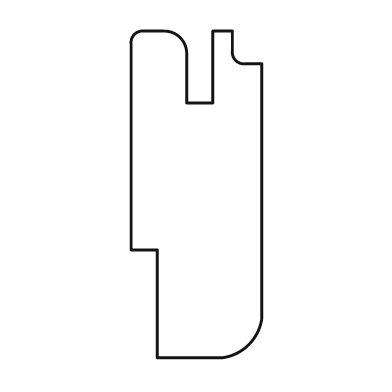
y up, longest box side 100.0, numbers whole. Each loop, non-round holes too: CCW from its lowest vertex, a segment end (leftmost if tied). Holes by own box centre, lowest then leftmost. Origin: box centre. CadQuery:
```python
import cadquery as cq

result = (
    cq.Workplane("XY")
    .moveTo(-12.0, -50.0)
    .lineTo(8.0, -50.0)
    .threePointArc((16.0, -46.0), (20.0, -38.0))
    .lineTo(20.0, 40.0)
    .lineTo(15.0, 40.0)
    .threePointArc((12.0, 41.0), (11.0, 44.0))
    .lineTo(11.0, 50.0)
    .lineTo(5.0, 50.0)
    .lineTo(5.0, 28.0)
    .lineTo(-3.0, 28.0)
    .lineTo(-3.0, 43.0)
    .threePointArc((-5.0, 48.0), (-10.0, 50.0))
    .lineTo(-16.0, 50.0)
    .threePointArc((-19.0, 49.0), (-20.0, 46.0))
    .lineTo(-20.0, -17.0)
    .lineTo(-12.0, -17.0)
    .close()
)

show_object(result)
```